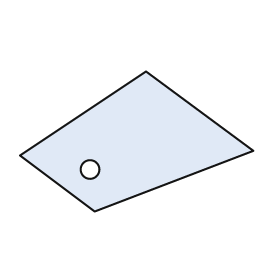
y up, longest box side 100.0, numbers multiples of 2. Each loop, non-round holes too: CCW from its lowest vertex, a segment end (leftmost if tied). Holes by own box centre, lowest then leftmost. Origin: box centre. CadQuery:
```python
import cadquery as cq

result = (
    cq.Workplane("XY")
    .moveTo(-18.0, -30.0)
    .lineTo(50.0, -4.0)
    .lineTo(4.0, 30.0)
    .lineTo(-50.0, -6.0)
    .close()
    .moveTo(-20.0, -12.0)
    .circle(4.0)
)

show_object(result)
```